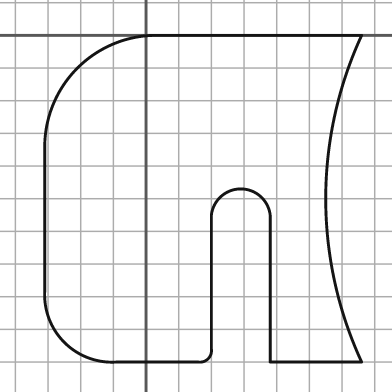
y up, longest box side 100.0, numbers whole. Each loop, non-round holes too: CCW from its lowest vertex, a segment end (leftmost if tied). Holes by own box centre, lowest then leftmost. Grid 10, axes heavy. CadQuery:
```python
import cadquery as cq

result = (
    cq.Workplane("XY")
    .moveTo(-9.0, -100.0)
    .lineTo(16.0, -100.0)
    .threePointArc((19.0, -99.0), (20.0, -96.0))
    .lineTo(20.0, -55.0)
    .threePointArc((29.0, -47.0), (38.0, -55.0))
    .lineTo(38.0, -100.0)
    .lineTo(66.0, -100.0)
    .threePointArc((55.0, -50.0), (66.0, 0.0))
    .lineTo(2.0, 0.0)
    .threePointArc((-21.0, -10.0), (-31.0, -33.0))
    .lineTo(-31.0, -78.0)
    .threePointArc((-25.0, -94.0), (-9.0, -100.0))
    .close()
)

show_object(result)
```